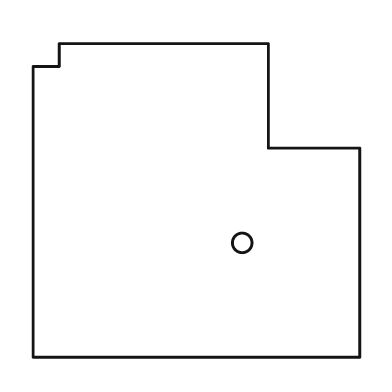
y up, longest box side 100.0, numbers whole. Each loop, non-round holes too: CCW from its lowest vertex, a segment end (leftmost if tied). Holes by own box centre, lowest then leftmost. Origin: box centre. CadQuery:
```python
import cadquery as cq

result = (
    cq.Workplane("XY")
    .moveTo(-50.0, -48.0)
    .lineTo(50.0, -48.0)
    .lineTo(50.0, 16.0)
    .lineTo(22.0, 16.0)
    .lineTo(22.0, 48.0)
    .lineTo(-42.0, 48.0)
    .lineTo(-42.0, 41.0)
    .lineTo(-50.0, 41.0)
    .close()
    .moveTo(14.0, -13.0)
    .circle(3.0)
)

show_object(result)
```